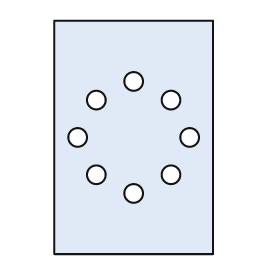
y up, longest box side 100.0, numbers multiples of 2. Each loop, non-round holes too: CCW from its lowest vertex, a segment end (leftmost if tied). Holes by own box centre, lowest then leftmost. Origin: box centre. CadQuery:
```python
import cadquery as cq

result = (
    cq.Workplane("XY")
    .moveTo(-34.0, -50.0)
    .lineTo(34.0, -50.0)
    .lineTo(34.0, 50.0)
    .lineTo(-34.0, 50.0)
    .close()
    .moveTo(0.0, -24.0)
    .circle(4.0)
    .moveTo(-16.0, -16.0)
    .circle(4.0)
    .moveTo(16.0, -16.0)
    .circle(4.0)
    .moveTo(-24.0, 0.0)
    .circle(4.0)
    .moveTo(24.0, 0.0)
    .circle(4.0)
    .moveTo(-16.0, 16.0)
    .circle(4.0)
    .moveTo(16.0, 16.0)
    .circle(4.0)
    .moveTo(0.0, 24.0)
    .circle(4.0)
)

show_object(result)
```